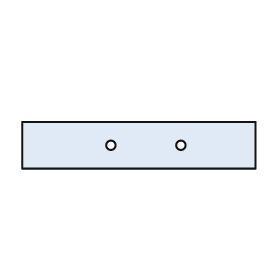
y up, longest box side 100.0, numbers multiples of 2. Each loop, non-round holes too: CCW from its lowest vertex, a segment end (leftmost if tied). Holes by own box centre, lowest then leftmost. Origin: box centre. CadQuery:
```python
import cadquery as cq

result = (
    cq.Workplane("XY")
    .moveTo(-50.0, -10.0)
    .lineTo(50.0, -10.0)
    .lineTo(50.0, 10.0)
    .lineTo(-50.0, 10.0)
    .close()
    .moveTo(-12.0, 0.0)
    .circle(2.0)
    .moveTo(18.0, 0.0)
    .circle(2.0)
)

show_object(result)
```